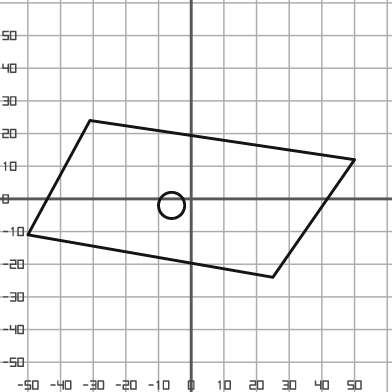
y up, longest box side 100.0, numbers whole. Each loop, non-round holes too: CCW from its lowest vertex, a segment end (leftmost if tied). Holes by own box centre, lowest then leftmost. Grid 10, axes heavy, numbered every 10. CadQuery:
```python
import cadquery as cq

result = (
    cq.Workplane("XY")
    .moveTo(25.0, -24.0)
    .lineTo(50.0, 12.0)
    .lineTo(-31.0, 24.0)
    .lineTo(-50.0, -11.0)
    .close()
    .moveTo(-6.0, -2.0)
    .circle(4.0)
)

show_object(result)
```